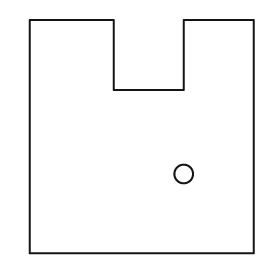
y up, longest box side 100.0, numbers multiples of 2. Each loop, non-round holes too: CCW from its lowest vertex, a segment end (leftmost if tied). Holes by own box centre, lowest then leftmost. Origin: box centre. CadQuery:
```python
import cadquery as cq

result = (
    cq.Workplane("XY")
    .moveTo(-48.0, -50.0)
    .lineTo(48.0, -50.0)
    .lineTo(48.0, 50.0)
    .lineTo(18.0, 50.0)
    .lineTo(18.0, 20.0)
    .lineTo(-12.0, 20.0)
    .lineTo(-12.0, 50.0)
    .lineTo(-48.0, 50.0)
    .close()
    .moveTo(18.0, -16.0)
    .circle(4.0)
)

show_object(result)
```